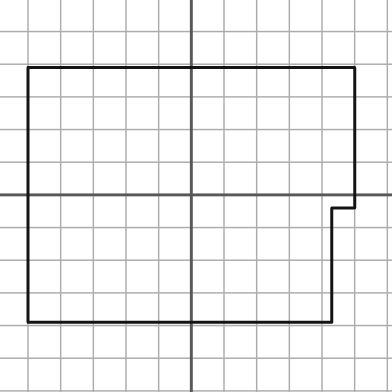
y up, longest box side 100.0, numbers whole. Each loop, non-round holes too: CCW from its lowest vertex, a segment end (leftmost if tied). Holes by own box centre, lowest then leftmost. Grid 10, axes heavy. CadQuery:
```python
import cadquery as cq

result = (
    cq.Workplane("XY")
    .moveTo(-50.0, -39.0)
    .lineTo(43.0, -39.0)
    .lineTo(43.0, -4.0)
    .lineTo(50.0, -4.0)
    .lineTo(50.0, 39.0)
    .lineTo(-50.0, 39.0)
    .close()
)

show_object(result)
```